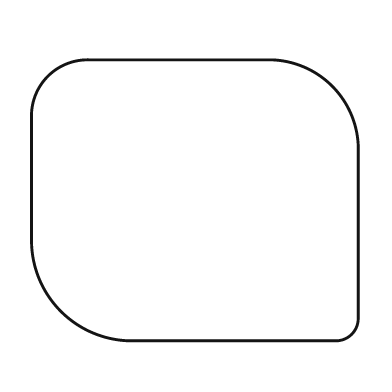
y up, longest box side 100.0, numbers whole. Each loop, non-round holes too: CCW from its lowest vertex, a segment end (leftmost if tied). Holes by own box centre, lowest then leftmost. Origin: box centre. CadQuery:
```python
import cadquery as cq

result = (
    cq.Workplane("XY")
    .moveTo(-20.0, -43.0)
    .lineTo(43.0, -43.0)
    .threePointArc((48.0, -41.0), (50.0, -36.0))
    .lineTo(50.0, 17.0)
    .threePointArc((42.0, 35.0), (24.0, 43.0))
    .lineTo(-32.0, 43.0)
    .threePointArc((-45.0, 38.0), (-50.0, 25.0))
    .lineTo(-50.0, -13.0)
    .threePointArc((-41.0, -34.0), (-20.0, -43.0))
    .close()
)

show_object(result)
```